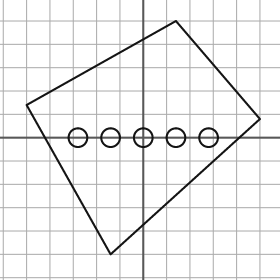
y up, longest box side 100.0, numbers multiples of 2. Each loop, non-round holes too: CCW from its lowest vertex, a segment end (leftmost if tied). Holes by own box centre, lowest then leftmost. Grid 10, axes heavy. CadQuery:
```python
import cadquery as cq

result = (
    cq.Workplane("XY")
    .moveTo(-14.0, -50.0)
    .lineTo(50.0, 8.0)
    .lineTo(14.0, 50.0)
    .lineTo(-50.0, 14.0)
    .close()
    .moveTo(-28.0, 0.0)
    .circle(4.0)
    .moveTo(-14.0, 0.0)
    .circle(4.0)
    .moveTo(0.0, 0.0)
    .circle(4.0)
    .moveTo(14.0, 0.0)
    .circle(4.0)
    .moveTo(28.0, 0.0)
    .circle(4.0)
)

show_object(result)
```